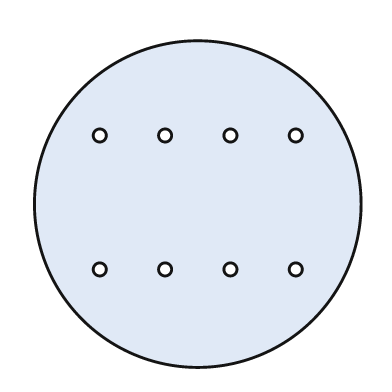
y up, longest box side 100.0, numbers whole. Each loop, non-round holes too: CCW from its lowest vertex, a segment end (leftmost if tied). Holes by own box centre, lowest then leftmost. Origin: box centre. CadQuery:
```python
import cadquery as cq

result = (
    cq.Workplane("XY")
    .moveTo(0.0, 0.0)
    .circle(50.0)
    .moveTo(-30.0, -20.0)
    .circle(2.0)
    .moveTo(-10.0, -20.0)
    .circle(2.0)
    .moveTo(10.0, -20.0)
    .circle(2.0)
    .moveTo(30.0, -20.0)
    .circle(2.0)
    .moveTo(-30.0, 21.0)
    .circle(2.0)
    .moveTo(-10.0, 21.0)
    .circle(2.0)
    .moveTo(10.0, 21.0)
    .circle(2.0)
    .moveTo(30.0, 21.0)
    .circle(2.0)
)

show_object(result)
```